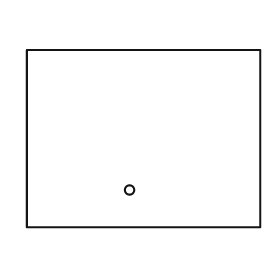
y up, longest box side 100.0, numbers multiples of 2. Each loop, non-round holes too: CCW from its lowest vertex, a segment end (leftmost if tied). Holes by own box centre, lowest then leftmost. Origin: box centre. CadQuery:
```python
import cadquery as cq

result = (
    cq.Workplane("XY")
    .moveTo(-50.0, -38.0)
    .lineTo(50.0, -38.0)
    .lineTo(50.0, 38.0)
    .lineTo(-50.0, 38.0)
    .close()
    .moveTo(-6.0, -22.0)
    .circle(2.0)
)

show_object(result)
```